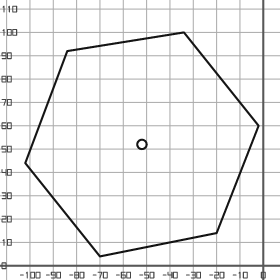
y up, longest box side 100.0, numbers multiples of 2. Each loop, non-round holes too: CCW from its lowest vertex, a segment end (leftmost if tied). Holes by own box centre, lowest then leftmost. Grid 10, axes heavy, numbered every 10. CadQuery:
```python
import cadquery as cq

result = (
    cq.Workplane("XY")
    .moveTo(-70.0, 4.0)
    .lineTo(-20.0, 14.0)
    .lineTo(-2.0, 60.0)
    .lineTo(-34.0, 100.0)
    .lineTo(-84.0, 92.0)
    .lineTo(-102.0, 44.0)
    .close()
    .moveTo(-52.0, 52.0)
    .circle(2.0)
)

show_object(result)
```